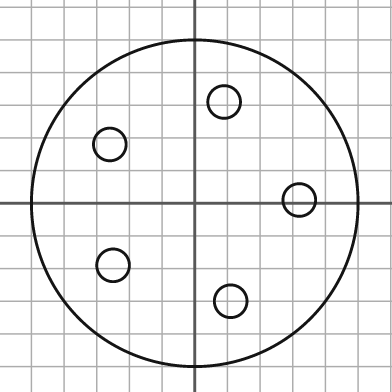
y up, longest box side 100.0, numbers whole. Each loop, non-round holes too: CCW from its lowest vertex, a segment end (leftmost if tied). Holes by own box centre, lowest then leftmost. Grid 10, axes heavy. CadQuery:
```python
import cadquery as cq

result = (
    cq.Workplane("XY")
    .moveTo(0.0, 0.0)
    .circle(50.0)
    .moveTo(11.0, -30.0)
    .circle(5.0)
    .moveTo(-25.0, -19.0)
    .circle(5.0)
    .moveTo(32.0, 1.0)
    .circle(5.0)
    .moveTo(-26.0, 18.0)
    .circle(5.0)
    .moveTo(9.0, 31.0)
    .circle(5.0)
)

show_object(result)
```